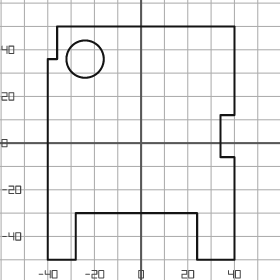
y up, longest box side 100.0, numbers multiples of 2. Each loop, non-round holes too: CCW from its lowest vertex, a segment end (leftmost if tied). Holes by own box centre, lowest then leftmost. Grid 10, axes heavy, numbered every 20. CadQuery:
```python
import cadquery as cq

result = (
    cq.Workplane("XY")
    .moveTo(-40.0, -50.0)
    .lineTo(-28.0, -50.0)
    .lineTo(-28.0, -30.0)
    .lineTo(24.0, -30.0)
    .lineTo(24.0, -50.0)
    .lineTo(40.0, -50.0)
    .lineTo(40.0, -6.0)
    .lineTo(34.0, -6.0)
    .lineTo(34.0, 12.0)
    .lineTo(40.0, 12.0)
    .lineTo(40.0, 50.0)
    .lineTo(-36.0, 50.0)
    .lineTo(-36.0, 36.0)
    .lineTo(-40.0, 36.0)
    .close()
    .moveTo(-24.0, 36.0)
    .circle(8.0)
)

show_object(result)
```